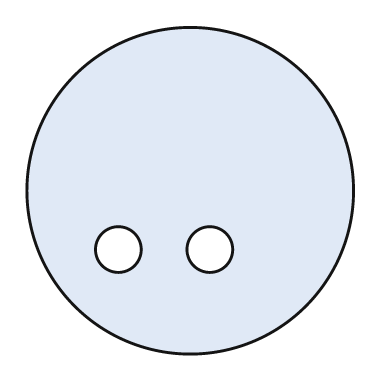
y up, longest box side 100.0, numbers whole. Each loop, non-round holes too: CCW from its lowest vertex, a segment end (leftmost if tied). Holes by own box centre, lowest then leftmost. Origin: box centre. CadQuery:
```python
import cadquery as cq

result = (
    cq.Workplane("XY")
    .moveTo(0.0, 0.0)
    .circle(50.0)
    .moveTo(-22.0, -18.0)
    .circle(7.0)
    .moveTo(6.0, -18.0)
    .circle(7.0)
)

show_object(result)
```